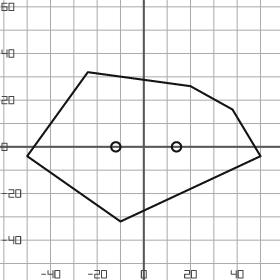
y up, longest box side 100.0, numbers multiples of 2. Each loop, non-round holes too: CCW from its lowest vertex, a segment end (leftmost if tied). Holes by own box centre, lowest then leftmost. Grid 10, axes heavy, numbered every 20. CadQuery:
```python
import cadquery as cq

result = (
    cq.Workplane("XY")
    .moveTo(-10.0, -32.0)
    .lineTo(50.0, -4.0)
    .lineTo(38.0, 16.0)
    .lineTo(20.0, 26.0)
    .lineTo(-24.0, 32.0)
    .lineTo(-50.0, -4.0)
    .close()
    .moveTo(-12.0, 0.0)
    .circle(2.0)
    .moveTo(14.0, 0.0)
    .circle(2.0)
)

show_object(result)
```